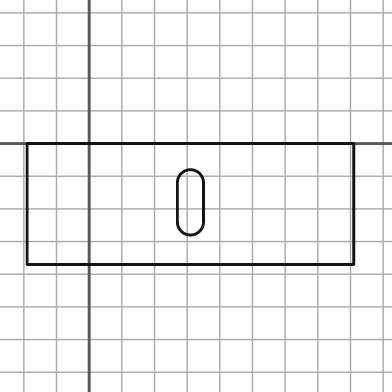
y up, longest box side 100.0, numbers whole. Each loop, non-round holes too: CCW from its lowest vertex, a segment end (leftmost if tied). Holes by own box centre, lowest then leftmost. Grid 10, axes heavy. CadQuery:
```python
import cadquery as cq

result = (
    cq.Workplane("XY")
    .moveTo(-19.0, -37.0)
    .lineTo(81.0, -37.0)
    .lineTo(81.0, 0.0)
    .lineTo(-19.0, 0.0)
    .close()
    .moveTo(27.0, -24.0)
    .threePointArc((31.0, -28.0), (35.0, -24.0))
    .lineTo(35.0, -12.0)
    .threePointArc((31.0, -8.0), (27.0, -12.0))
    .close()
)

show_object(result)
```